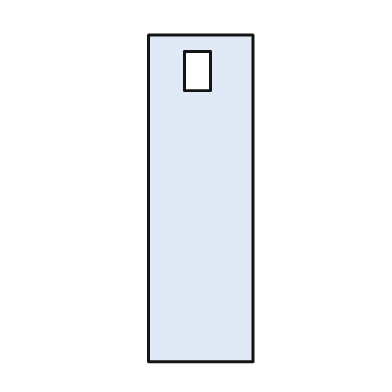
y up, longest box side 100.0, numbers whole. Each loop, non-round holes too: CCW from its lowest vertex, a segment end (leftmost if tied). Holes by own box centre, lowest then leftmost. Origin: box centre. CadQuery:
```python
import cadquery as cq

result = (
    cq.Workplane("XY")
    .moveTo(-16.0, -50.0)
    .lineTo(16.0, -50.0)
    .lineTo(16.0, 50.0)
    .lineTo(-16.0, 50.0)
    .close()
    .moveTo(-5.0, 33.0)
    .lineTo(3.0, 33.0)
    .lineTo(3.0, 45.0)
    .lineTo(-5.0, 45.0)
    .close()
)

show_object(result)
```